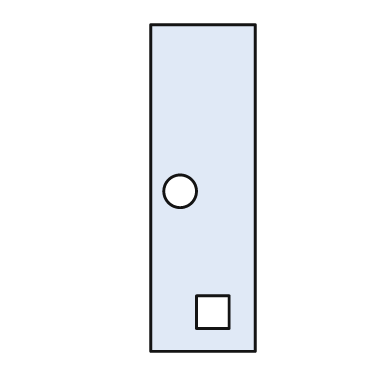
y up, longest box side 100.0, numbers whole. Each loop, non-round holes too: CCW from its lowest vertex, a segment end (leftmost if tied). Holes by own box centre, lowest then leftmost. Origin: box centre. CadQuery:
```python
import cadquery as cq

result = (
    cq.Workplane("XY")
    .moveTo(-16.0, -50.0)
    .lineTo(16.0, -50.0)
    .lineTo(16.0, 50.0)
    .lineTo(-16.0, 50.0)
    .close()
    .moveTo(-2.0, -43.0)
    .lineTo(8.0, -43.0)
    .lineTo(8.0, -33.0)
    .lineTo(-2.0, -33.0)
    .close()
    .moveTo(-7.0, -1.0)
    .circle(5.0)
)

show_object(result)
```